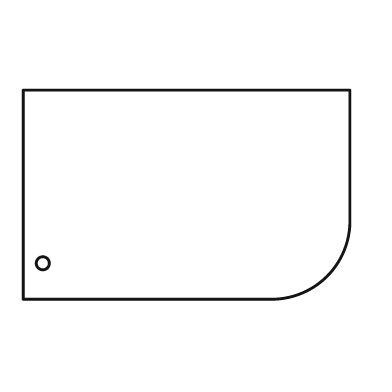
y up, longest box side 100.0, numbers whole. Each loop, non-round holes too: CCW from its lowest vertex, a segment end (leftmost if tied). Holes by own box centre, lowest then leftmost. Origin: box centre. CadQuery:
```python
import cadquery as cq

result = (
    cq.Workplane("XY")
    .moveTo(-50.0, -32.0)
    .lineTo(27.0, -32.0)
    .threePointArc((43.0, -25.0), (50.0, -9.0))
    .lineTo(50.0, 32.0)
    .lineTo(-50.0, 32.0)
    .close()
    .moveTo(-44.0, -21.0)
    .circle(2.0)
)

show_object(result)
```